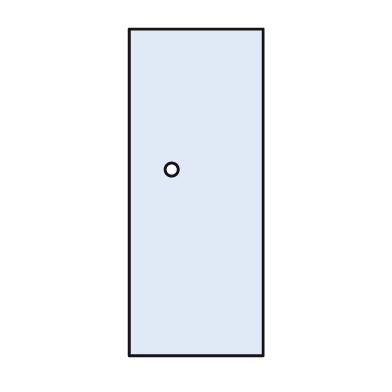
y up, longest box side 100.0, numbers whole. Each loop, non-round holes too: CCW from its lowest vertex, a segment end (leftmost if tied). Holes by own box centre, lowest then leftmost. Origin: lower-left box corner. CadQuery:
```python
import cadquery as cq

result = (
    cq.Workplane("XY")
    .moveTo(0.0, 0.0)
    .lineTo(41.0, 0.0)
    .lineTo(41.0, 100.0)
    .lineTo(0.0, 100.0)
    .close()
    .moveTo(13.0, 57.0)
    .circle(2.0)
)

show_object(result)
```